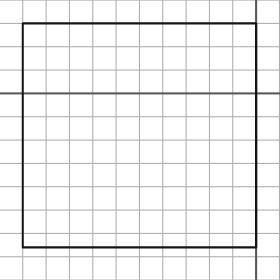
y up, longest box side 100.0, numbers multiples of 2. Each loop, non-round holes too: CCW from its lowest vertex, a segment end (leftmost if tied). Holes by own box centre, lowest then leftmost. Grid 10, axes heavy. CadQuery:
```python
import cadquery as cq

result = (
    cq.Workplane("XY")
    .moveTo(-100.0, -66.0)
    .lineTo(0.0, -66.0)
    .lineTo(0.0, 30.0)
    .lineTo(-100.0, 30.0)
    .close()
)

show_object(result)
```